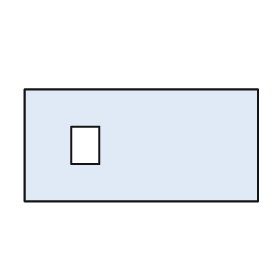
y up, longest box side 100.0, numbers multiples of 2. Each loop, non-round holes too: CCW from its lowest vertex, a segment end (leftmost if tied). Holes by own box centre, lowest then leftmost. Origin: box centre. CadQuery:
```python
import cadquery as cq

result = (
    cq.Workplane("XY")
    .moveTo(-50.0, -24.0)
    .lineTo(50.0, -24.0)
    .lineTo(50.0, 24.0)
    .lineTo(-50.0, 24.0)
    .close()
    .moveTo(-30.0, -8.0)
    .lineTo(-18.0, -8.0)
    .lineTo(-18.0, 8.0)
    .lineTo(-30.0, 8.0)
    .close()
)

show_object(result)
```